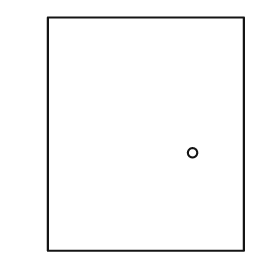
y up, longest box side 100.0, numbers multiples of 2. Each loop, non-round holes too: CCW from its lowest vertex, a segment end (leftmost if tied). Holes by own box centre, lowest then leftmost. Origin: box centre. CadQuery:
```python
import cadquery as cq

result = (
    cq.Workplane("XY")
    .moveTo(-42.0, -50.0)
    .lineTo(42.0, -50.0)
    .lineTo(42.0, 50.0)
    .lineTo(-42.0, 50.0)
    .close()
    .moveTo(20.0, -8.0)
    .circle(2.0)
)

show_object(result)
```